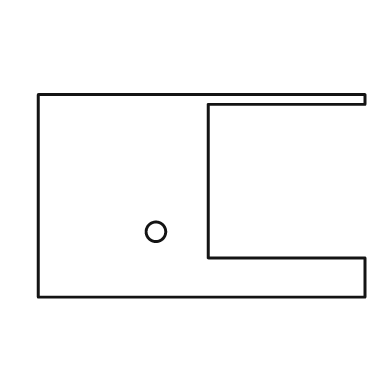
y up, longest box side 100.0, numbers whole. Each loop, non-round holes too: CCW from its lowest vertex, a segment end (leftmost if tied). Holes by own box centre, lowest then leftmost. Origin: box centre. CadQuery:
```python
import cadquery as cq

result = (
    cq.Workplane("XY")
    .moveTo(-50.0, -31.0)
    .lineTo(50.0, -31.0)
    .lineTo(50.0, -19.0)
    .lineTo(2.0, -19.0)
    .lineTo(2.0, 28.0)
    .lineTo(50.0, 28.0)
    .lineTo(50.0, 31.0)
    .lineTo(-50.0, 31.0)
    .close()
    .moveTo(-14.0, -11.0)
    .circle(3.0)
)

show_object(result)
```